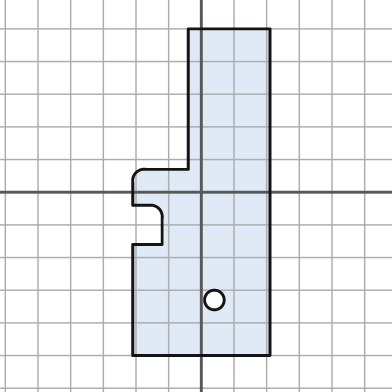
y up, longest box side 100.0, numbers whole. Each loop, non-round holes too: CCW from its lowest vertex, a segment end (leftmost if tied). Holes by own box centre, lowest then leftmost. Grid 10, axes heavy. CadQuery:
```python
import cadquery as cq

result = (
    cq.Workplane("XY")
    .moveTo(-21.0, -50.0)
    .lineTo(21.0, -50.0)
    .lineTo(21.0, 50.0)
    .lineTo(-4.0, 50.0)
    .lineTo(-4.0, 7.0)
    .lineTo(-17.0, 7.0)
    .threePointArc((-20.0, 6.0), (-21.0, 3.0))
    .lineTo(-21.0, -4.0)
    .lineTo(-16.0, -4.0)
    .threePointArc((-13.0, -5.0), (-12.0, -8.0))
    .lineTo(-12.0, -16.0)
    .lineTo(-21.0, -16.0)
    .close()
    .moveTo(4.0, -33.0)
    .circle(3.0)
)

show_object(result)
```